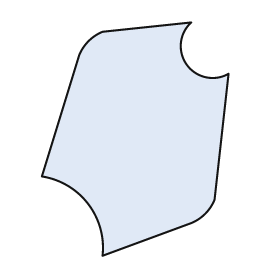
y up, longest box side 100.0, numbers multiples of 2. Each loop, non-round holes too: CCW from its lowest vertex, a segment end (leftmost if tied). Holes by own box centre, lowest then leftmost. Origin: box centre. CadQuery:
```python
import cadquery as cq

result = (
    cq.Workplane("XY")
    .moveTo(-14.0, -50.0)
    .lineTo(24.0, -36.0)
    .threePointArc((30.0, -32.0), (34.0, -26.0))
    .lineTo(40.0, 28.0)
    .threePointArc((22.0, 32.0), (24.0, 50.0))
    .lineTo(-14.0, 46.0)
    .threePointArc((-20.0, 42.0), (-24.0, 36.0))
    .lineTo(-40.0, -16.0)
    .threePointArc((-20.0, -28.0), (-14.0, -50.0))
    .close()
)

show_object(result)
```